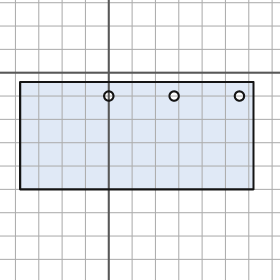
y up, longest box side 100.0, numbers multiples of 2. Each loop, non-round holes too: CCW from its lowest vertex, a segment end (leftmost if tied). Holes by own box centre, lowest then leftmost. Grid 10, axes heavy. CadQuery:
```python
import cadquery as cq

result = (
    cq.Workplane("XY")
    .moveTo(-38.0, -50.0)
    .lineTo(62.0, -50.0)
    .lineTo(62.0, -4.0)
    .lineTo(-38.0, -4.0)
    .close()
    .moveTo(0.0, -10.0)
    .circle(2.0)
    .moveTo(28.0, -10.0)
    .circle(2.0)
    .moveTo(56.0, -10.0)
    .circle(2.0)
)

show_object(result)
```